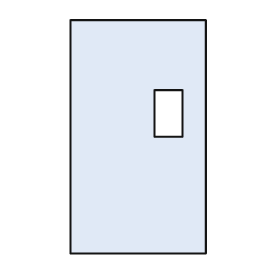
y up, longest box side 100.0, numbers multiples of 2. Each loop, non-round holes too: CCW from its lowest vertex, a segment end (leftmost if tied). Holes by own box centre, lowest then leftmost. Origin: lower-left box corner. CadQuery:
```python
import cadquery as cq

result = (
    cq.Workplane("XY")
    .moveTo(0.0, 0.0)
    .lineTo(58.0, 0.0)
    .lineTo(58.0, 100.0)
    .lineTo(0.0, 100.0)
    .close()
    .moveTo(36.0, 50.0)
    .lineTo(48.0, 50.0)
    .lineTo(48.0, 70.0)
    .lineTo(36.0, 70.0)
    .close()
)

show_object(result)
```